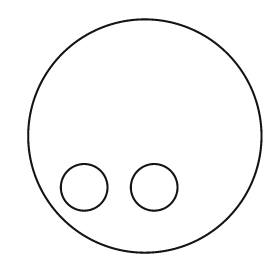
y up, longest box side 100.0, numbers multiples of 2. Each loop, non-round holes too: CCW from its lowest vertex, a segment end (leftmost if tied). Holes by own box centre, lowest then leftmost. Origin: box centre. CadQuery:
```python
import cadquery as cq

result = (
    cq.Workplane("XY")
    .moveTo(0.0, 0.0)
    .circle(50.0)
    .moveTo(-26.0, -22.0)
    .circle(10.0)
    .moveTo(4.0, -22.0)
    .circle(10.0)
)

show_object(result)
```